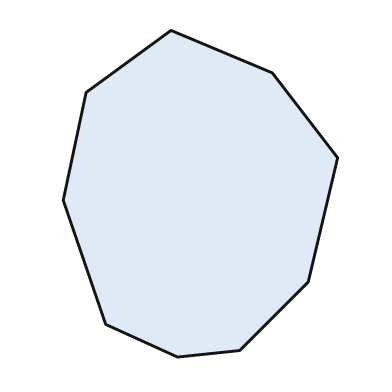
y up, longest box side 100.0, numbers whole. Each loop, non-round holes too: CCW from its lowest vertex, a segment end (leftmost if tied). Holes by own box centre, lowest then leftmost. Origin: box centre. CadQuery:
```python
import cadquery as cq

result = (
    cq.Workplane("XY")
    .moveTo(-7.0, -50.0)
    .lineTo(12.0, -48.0)
    .lineTo(33.0, -27.0)
    .lineTo(42.0, 11.0)
    .lineTo(22.0, 37.0)
    .lineTo(-9.0, 50.0)
    .lineTo(-35.0, 31.0)
    .lineTo(-42.0, -2.0)
    .lineTo(-29.0, -40.0)
    .close()
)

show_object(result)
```